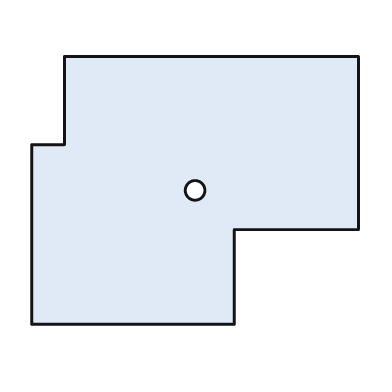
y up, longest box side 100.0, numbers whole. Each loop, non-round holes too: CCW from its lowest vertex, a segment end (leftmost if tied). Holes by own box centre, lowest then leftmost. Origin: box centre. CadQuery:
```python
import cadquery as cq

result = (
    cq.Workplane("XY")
    .moveTo(-50.0, -41.0)
    .lineTo(12.0, -41.0)
    .lineTo(12.0, -12.0)
    .lineTo(50.0, -12.0)
    .lineTo(50.0, 41.0)
    .lineTo(-40.0, 41.0)
    .lineTo(-40.0, 14.0)
    .lineTo(-50.0, 14.0)
    .close()
    .moveTo(0.0, 0.0)
    .circle(3.0)
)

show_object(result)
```